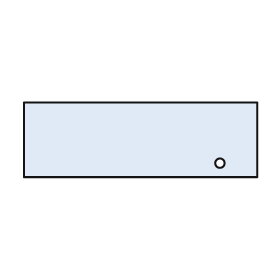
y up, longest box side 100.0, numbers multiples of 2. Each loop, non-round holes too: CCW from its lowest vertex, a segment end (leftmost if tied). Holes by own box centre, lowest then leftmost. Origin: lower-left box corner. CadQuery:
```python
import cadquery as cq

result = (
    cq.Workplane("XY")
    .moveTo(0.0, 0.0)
    .lineTo(100.0, 0.0)
    .lineTo(100.0, 32.0)
    .lineTo(0.0, 32.0)
    .close()
    .moveTo(84.0, 6.0)
    .circle(2.0)
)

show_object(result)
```